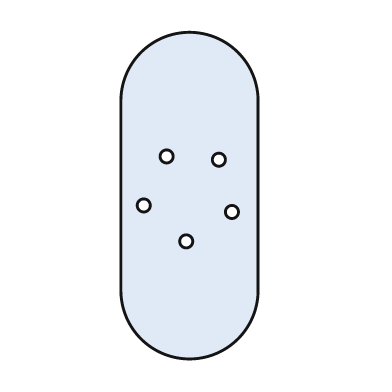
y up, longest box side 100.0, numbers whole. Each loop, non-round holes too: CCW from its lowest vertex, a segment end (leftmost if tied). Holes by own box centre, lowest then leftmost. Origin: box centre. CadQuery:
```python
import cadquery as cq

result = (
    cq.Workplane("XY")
    .moveTo(-21.0, -29.0)
    .threePointArc((0.0, -50.0), (21.0, -29.0))
    .lineTo(21.0, 29.0)
    .threePointArc((0.0, 50.0), (-21.0, 29.0))
    .close()
    .moveTo(-1.0, -14.0)
    .circle(2.0)
    .moveTo(13.0, -5.0)
    .circle(2.0)
    .moveTo(-14.0, -3.0)
    .circle(2.0)
    .moveTo(9.0, 11.0)
    .circle(2.0)
    .moveTo(-7.0, 12.0)
    .circle(2.0)
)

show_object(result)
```